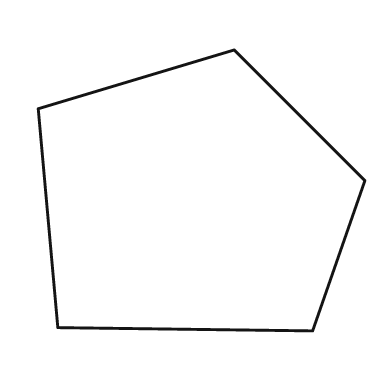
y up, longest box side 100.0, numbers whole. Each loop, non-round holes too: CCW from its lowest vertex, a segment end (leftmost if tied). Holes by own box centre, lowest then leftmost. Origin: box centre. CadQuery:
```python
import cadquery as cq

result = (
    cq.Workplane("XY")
    .moveTo(34.0, -43.0)
    .lineTo(50.0, 3.0)
    .lineTo(10.0, 43.0)
    .lineTo(-50.0, 25.0)
    .lineTo(-44.0, -42.0)
    .close()
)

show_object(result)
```